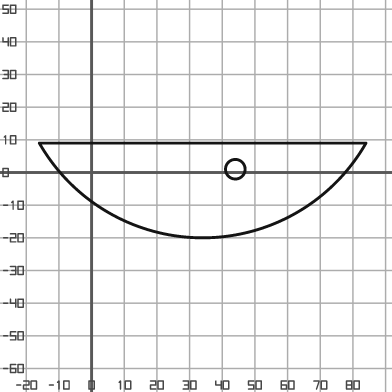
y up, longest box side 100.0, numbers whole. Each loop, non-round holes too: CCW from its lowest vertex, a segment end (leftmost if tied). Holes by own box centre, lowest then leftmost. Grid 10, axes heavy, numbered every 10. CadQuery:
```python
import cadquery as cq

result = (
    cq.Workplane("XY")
    .moveTo(-16.0, 9.0)
    .threePointArc((34.0, -20.0), (84.0, 9.0))
    .close()
    .moveTo(44.0, 1.0)
    .circle(3.0)
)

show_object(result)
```